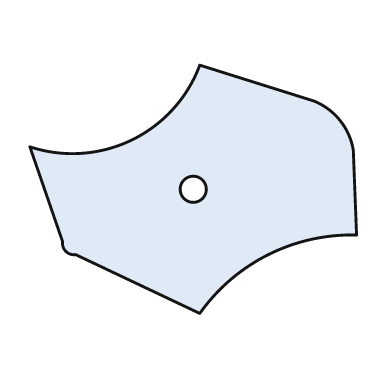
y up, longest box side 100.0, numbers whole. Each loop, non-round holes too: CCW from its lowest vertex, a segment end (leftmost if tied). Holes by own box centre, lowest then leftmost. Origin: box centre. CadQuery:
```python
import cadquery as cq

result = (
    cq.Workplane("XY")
    .moveTo(2.0, -38.0)
    .threePointArc((23.0, -20.0), (50.0, -14.0))
    .lineTo(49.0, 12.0)
    .threePointArc((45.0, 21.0), (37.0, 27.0))
    .lineTo(2.0, 38.0)
    .threePointArc((-19.0, 15.0), (-50.0, 13.0))
    .lineTo(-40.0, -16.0)
    .threePointArc((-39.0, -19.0), (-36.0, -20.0))
    .close()
    .moveTo(0.0, 0.0)
    .circle(4.0)
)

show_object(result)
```